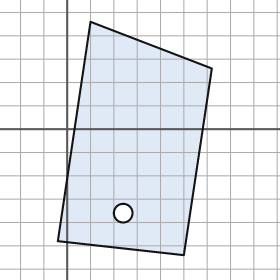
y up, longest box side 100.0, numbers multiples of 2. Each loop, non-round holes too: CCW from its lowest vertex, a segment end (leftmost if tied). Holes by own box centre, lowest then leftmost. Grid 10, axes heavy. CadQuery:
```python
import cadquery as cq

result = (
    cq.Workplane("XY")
    .moveTo(50.0, -54.0)
    .lineTo(62.0, 26.0)
    .lineTo(10.0, 46.0)
    .lineTo(-4.0, -48.0)
    .close()
    .moveTo(24.0, -36.0)
    .circle(4.0)
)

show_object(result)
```